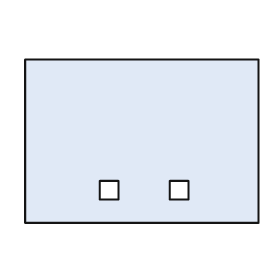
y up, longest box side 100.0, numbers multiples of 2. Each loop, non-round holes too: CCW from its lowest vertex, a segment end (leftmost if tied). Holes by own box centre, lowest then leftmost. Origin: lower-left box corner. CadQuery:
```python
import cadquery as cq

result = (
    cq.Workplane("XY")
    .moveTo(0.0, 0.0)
    .lineTo(100.0, 0.0)
    .lineTo(100.0, 70.0)
    .lineTo(0.0, 70.0)
    .close()
    .moveTo(32.0, 10.0)
    .lineTo(40.0, 10.0)
    .lineTo(40.0, 18.0)
    .lineTo(32.0, 18.0)
    .close()
    .moveTo(62.0, 10.0)
    .lineTo(70.0, 10.0)
    .lineTo(70.0, 18.0)
    .lineTo(62.0, 18.0)
    .close()
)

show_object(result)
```